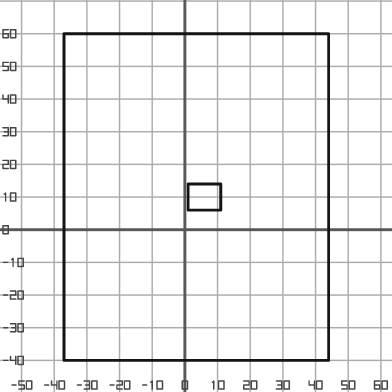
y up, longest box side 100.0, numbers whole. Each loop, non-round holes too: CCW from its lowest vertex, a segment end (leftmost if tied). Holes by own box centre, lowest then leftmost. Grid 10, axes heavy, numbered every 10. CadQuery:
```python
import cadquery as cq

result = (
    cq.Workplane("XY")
    .moveTo(-37.0, -40.0)
    .lineTo(44.0, -40.0)
    .lineTo(44.0, 60.0)
    .lineTo(-37.0, 60.0)
    .close()
    .moveTo(1.0, 6.0)
    .lineTo(11.0, 6.0)
    .lineTo(11.0, 14.0)
    .lineTo(1.0, 14.0)
    .close()
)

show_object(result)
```